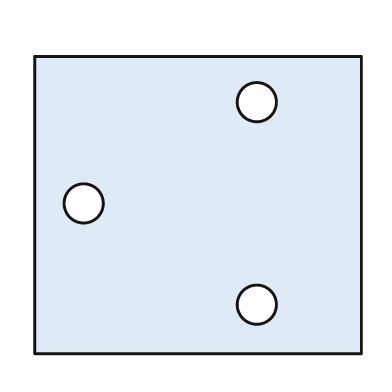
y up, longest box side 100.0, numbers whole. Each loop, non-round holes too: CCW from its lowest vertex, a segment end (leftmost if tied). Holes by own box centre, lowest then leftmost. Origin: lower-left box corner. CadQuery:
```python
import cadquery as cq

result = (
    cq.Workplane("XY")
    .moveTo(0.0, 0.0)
    .lineTo(100.0, 0.0)
    .lineTo(100.0, 91.0)
    .lineTo(0.0, 91.0)
    .close()
    .moveTo(68.0, 15.0)
    .circle(6.0)
    .moveTo(15.0, 46.0)
    .circle(6.0)
    .moveTo(68.0, 77.0)
    .circle(6.0)
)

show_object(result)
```